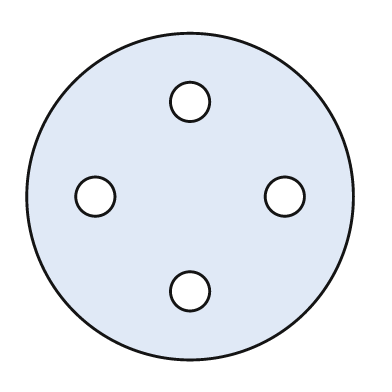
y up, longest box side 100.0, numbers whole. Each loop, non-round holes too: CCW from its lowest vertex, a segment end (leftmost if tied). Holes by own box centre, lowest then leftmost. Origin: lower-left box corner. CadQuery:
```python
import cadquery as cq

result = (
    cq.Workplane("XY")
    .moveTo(50.0, 50.0)
    .circle(50.0)
    .moveTo(50.0, 21.0)
    .circle(6.0)
    .moveTo(21.0, 50.0)
    .circle(6.0)
    .moveTo(79.0, 50.0)
    .circle(6.0)
    .moveTo(50.0, 79.0)
    .circle(6.0)
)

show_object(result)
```